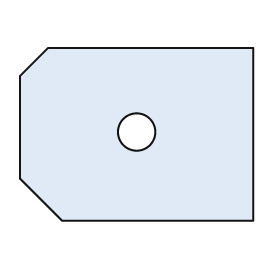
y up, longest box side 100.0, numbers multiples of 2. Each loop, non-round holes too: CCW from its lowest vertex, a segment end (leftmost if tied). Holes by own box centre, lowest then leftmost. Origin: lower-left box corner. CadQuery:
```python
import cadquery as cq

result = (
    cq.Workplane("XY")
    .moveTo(18.0, 0.0)
    .lineTo(100.0, 0.0)
    .lineTo(100.0, 74.0)
    .lineTo(12.0, 74.0)
    .lineTo(0.0, 62.0)
    .lineTo(0.0, 18.0)
    .close()
    .moveTo(50.0, 38.0)
    .circle(8.0)
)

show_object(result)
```